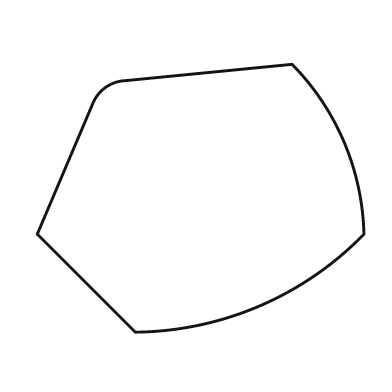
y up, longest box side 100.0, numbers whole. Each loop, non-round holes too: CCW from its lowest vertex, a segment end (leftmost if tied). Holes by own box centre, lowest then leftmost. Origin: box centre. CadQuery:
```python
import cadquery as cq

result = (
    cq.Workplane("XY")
    .moveTo(-20.0, -41.0)
    .threePointArc((18.0, -33.0), (50.0, -11.0))
    .threePointArc((44.0, 17.0), (28.0, 41.0))
    .lineTo(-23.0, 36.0)
    .threePointArc((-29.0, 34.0), (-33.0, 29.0))
    .lineTo(-50.0, -11.0)
    .close()
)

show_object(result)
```